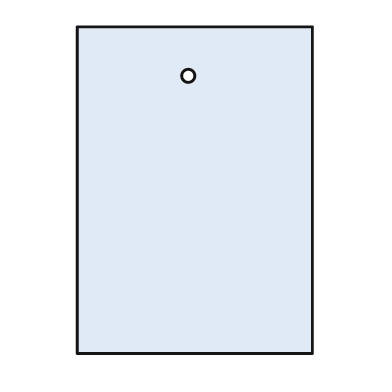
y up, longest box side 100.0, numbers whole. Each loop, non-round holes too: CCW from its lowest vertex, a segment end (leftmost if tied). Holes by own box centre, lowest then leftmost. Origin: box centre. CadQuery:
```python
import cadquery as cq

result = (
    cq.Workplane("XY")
    .moveTo(-36.0, -50.0)
    .lineTo(36.0, -50.0)
    .lineTo(36.0, 50.0)
    .lineTo(-36.0, 50.0)
    .close()
    .moveTo(-2.0, 35.0)
    .circle(2.0)
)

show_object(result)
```